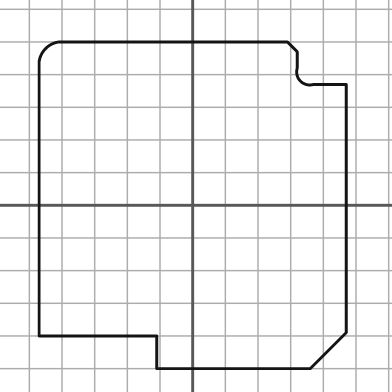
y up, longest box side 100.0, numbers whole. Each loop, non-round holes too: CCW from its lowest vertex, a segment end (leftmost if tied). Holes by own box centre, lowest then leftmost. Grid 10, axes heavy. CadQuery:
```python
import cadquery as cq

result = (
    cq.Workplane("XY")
    .moveTo(-11.0, -50.0)
    .lineTo(36.0, -50.0)
    .lineTo(47.0, -39.0)
    .lineTo(47.0, 37.0)
    .lineTo(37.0, 37.0)
    .threePointArc((33.0, 38.0), (32.0, 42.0))
    .lineTo(32.0, 47.0)
    .lineTo(29.0, 50.0)
    .lineTo(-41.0, 50.0)
    .threePointArc((-45.0, 48.0), (-47.0, 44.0))
    .lineTo(-47.0, -40.0)
    .lineTo(-11.0, -40.0)
    .close()
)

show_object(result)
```